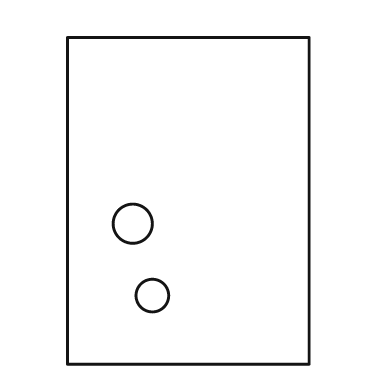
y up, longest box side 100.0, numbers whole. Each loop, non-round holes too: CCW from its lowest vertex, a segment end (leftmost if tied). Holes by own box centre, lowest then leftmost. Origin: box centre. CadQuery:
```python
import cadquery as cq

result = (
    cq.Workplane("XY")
    .moveTo(-37.0, -50.0)
    .lineTo(37.0, -50.0)
    .lineTo(37.0, 50.0)
    .lineTo(-37.0, 50.0)
    .close()
    .moveTo(-11.0, -29.0)
    .circle(5.0)
    .moveTo(-17.0, -7.0)
    .circle(6.0)
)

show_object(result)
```